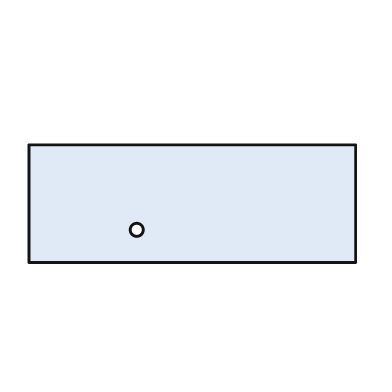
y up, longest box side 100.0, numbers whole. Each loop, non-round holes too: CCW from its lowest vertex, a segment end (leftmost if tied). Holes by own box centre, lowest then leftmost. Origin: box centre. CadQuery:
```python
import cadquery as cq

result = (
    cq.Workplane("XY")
    .moveTo(-50.0, -18.0)
    .lineTo(50.0, -18.0)
    .lineTo(50.0, 18.0)
    .lineTo(-50.0, 18.0)
    .close()
    .moveTo(-17.0, -8.0)
    .circle(2.0)
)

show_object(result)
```